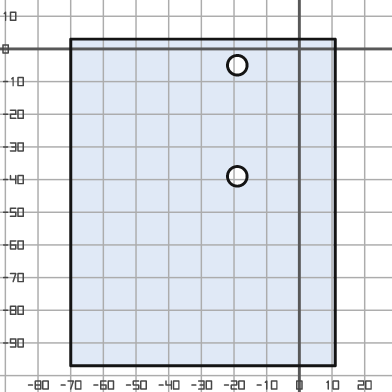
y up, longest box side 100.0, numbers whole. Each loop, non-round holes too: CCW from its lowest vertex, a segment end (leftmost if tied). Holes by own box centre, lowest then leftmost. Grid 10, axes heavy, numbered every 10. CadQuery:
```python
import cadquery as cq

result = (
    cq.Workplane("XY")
    .moveTo(-70.0, -97.0)
    .lineTo(11.0, -97.0)
    .lineTo(11.0, 3.0)
    .lineTo(-70.0, 3.0)
    .close()
    .moveTo(-19.0, -39.0)
    .circle(3.0)
    .moveTo(-19.0, -5.0)
    .circle(3.0)
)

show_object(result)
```